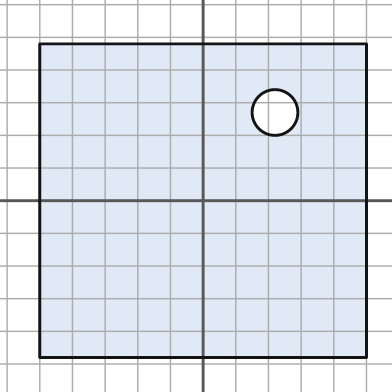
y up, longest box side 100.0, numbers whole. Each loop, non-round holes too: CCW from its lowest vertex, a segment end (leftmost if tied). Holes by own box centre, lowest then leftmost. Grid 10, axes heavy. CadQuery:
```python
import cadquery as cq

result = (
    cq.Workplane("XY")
    .moveTo(-50.0, -48.0)
    .lineTo(50.0, -48.0)
    .lineTo(50.0, 48.0)
    .lineTo(-50.0, 48.0)
    .close()
    .moveTo(22.0, 27.0)
    .circle(7.0)
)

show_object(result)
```